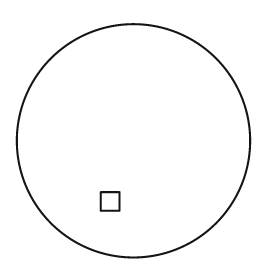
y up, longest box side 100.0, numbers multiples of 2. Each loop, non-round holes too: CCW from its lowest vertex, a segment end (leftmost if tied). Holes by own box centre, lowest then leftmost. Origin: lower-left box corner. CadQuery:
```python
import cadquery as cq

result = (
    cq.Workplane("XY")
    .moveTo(50.0, 50.0)
    .circle(50.0)
    .moveTo(36.0, 20.0)
    .lineTo(44.0, 20.0)
    .lineTo(44.0, 28.0)
    .lineTo(36.0, 28.0)
    .close()
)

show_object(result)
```